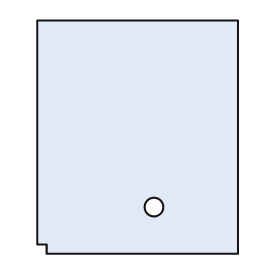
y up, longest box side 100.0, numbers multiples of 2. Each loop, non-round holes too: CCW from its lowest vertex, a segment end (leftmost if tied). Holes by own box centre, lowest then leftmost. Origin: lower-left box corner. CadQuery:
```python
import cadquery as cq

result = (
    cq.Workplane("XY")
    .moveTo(4.0, 0.0)
    .lineTo(86.0, 0.0)
    .lineTo(86.0, 100.0)
    .lineTo(0.0, 100.0)
    .lineTo(0.0, 4.0)
    .lineTo(4.0, 4.0)
    .close()
    .moveTo(50.0, 20.0)
    .circle(4.0)
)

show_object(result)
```